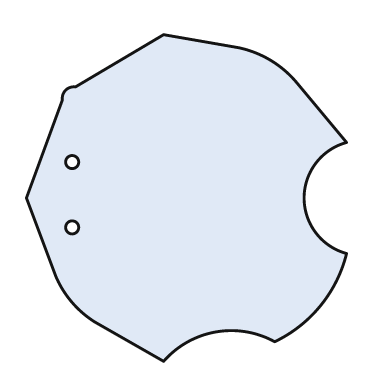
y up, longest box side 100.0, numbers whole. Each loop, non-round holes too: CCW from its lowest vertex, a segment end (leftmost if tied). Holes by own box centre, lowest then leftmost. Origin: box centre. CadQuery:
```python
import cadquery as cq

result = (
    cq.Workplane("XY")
    .moveTo(-7.0, -50.0)
    .threePointArc((9.0, -41.0), (27.0, -44.0))
    .threePointArc((41.0, -33.0), (49.0, -17.0))
    .threePointArc((36.0, 0.0), (49.0, 17.0))
    .lineTo(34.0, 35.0)
    .threePointArc((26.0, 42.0), (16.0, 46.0))
    .lineTo(-7.0, 50.0)
    .lineTo(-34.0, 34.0)
    .threePointArc((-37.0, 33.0), (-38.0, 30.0))
    .lineTo(-49.0, 0.0)
    .lineTo(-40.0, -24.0)
    .threePointArc((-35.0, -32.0), (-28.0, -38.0))
    .close()
    .moveTo(-35.0, -9.0)
    .circle(2.0)
    .moveTo(-35.0, 11.0)
    .circle(2.0)
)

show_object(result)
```